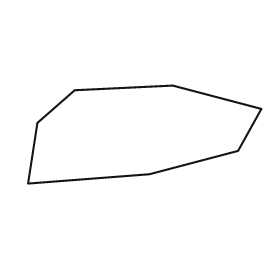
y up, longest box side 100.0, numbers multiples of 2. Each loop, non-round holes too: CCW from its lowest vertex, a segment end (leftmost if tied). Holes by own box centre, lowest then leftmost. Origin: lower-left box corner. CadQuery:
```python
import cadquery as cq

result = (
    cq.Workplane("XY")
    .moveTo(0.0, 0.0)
    .lineTo(52.0, 4.0)
    .lineTo(90.0, 14.0)
    .lineTo(100.0, 32.0)
    .lineTo(62.0, 42.0)
    .lineTo(20.0, 40.0)
    .lineTo(4.0, 26.0)
    .close()
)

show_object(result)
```